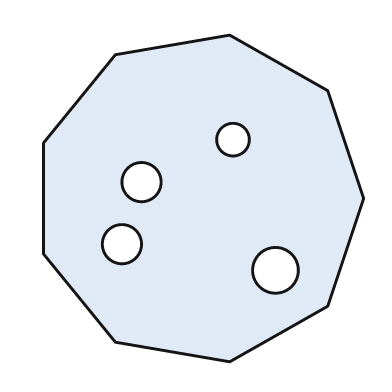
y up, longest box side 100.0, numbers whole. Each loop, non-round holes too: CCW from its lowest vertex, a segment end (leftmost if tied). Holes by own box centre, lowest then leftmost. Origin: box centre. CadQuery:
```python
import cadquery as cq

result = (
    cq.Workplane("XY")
    .moveTo(8.0, -50.0)
    .lineTo(38.0, -33.0)
    .lineTo(49.0, 0.0)
    .lineTo(38.0, 33.0)
    .lineTo(8.0, 50.0)
    .lineTo(-27.0, 44.0)
    .lineTo(-49.0, 17.0)
    .lineTo(-49.0, -17.0)
    .lineTo(-27.0, -44.0)
    .close()
    .moveTo(22.0, -22.0)
    .circle(7.0)
    .moveTo(-25.0, -14.0)
    .circle(6.0)
    .moveTo(-19.0, 5.0)
    .circle(6.0)
    .moveTo(9.0, 18.0)
    .circle(5.0)
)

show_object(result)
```